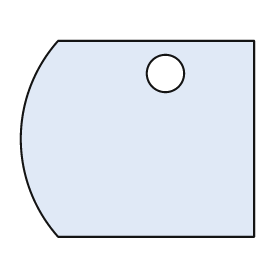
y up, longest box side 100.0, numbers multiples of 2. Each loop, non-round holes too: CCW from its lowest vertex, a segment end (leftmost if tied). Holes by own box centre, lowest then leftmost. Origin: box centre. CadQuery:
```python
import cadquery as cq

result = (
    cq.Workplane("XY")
    .moveTo(-34.0, -42.0)
    .lineTo(50.0, -42.0)
    .lineTo(50.0, 42.0)
    .lineTo(-34.0, 42.0)
    .threePointArc((-50.0, 0.0), (-34.0, -42.0))
    .close()
    .moveTo(12.0, 28.0)
    .circle(8.0)
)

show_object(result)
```